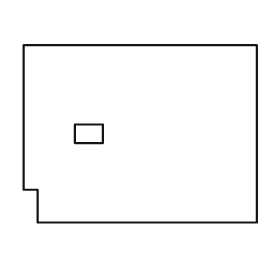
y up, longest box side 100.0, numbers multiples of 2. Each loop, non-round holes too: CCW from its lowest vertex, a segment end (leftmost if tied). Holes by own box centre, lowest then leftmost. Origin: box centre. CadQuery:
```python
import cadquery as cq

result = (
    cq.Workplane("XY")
    .moveTo(-44.0, -38.0)
    .lineTo(50.0, -38.0)
    .lineTo(50.0, 38.0)
    .lineTo(-50.0, 38.0)
    .lineTo(-50.0, -24.0)
    .lineTo(-44.0, -24.0)
    .close()
    .moveTo(-28.0, -4.0)
    .lineTo(-16.0, -4.0)
    .lineTo(-16.0, 4.0)
    .lineTo(-28.0, 4.0)
    .close()
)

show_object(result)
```